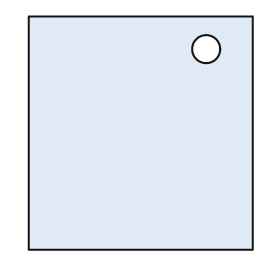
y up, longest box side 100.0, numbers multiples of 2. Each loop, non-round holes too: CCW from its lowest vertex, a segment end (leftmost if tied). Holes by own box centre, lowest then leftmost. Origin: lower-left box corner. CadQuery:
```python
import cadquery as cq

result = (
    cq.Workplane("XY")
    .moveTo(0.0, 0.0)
    .lineTo(96.0, 0.0)
    .lineTo(96.0, 100.0)
    .lineTo(0.0, 100.0)
    .close()
    .moveTo(76.0, 86.0)
    .circle(6.0)
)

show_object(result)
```